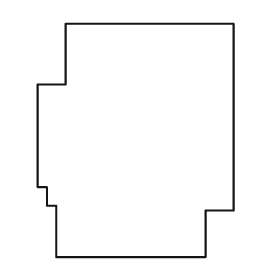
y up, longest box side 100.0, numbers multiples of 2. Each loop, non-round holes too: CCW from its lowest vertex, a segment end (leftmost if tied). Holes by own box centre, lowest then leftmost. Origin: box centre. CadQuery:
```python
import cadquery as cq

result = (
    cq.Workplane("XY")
    .moveTo(-34.0, -50.0)
    .lineTo(30.0, -50.0)
    .lineTo(30.0, -30.0)
    .lineTo(42.0, -30.0)
    .lineTo(42.0, 50.0)
    .lineTo(-30.0, 50.0)
    .lineTo(-30.0, 24.0)
    .lineTo(-42.0, 24.0)
    .lineTo(-42.0, -20.0)
    .lineTo(-38.0, -20.0)
    .lineTo(-38.0, -28.0)
    .lineTo(-34.0, -28.0)
    .close()
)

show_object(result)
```